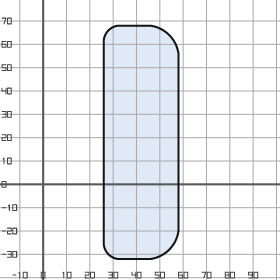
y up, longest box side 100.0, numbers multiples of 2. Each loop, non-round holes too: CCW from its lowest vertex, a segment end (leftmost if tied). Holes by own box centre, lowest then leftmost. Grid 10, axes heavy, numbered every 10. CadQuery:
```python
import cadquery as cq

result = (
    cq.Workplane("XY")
    .moveTo(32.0, -32.0)
    .lineTo(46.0, -32.0)
    .threePointArc((54.0, -28.0), (58.0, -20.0))
    .lineTo(58.0, 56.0)
    .threePointArc((54.0, 64.0), (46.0, 68.0))
    .lineTo(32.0, 68.0)
    .threePointArc((28.0, 66.0), (26.0, 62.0))
    .lineTo(26.0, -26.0)
    .threePointArc((28.0, -30.0), (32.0, -32.0))
    .close()
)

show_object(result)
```